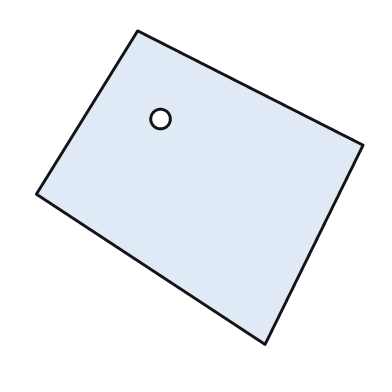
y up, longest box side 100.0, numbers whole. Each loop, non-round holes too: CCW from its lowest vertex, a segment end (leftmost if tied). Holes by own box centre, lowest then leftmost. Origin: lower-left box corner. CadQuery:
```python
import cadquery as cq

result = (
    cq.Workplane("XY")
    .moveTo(70.0, 0.0)
    .lineTo(100.0, 61.0)
    .lineTo(31.0, 96.0)
    .lineTo(0.0, 46.0)
    .close()
    .moveTo(38.0, 69.0)
    .circle(3.0)
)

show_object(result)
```